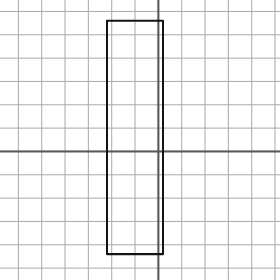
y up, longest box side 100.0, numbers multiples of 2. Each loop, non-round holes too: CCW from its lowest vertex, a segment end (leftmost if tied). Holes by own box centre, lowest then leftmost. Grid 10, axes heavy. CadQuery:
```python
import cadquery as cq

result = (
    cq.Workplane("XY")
    .moveTo(-22.0, -44.0)
    .lineTo(2.0, -44.0)
    .lineTo(2.0, 56.0)
    .lineTo(-22.0, 56.0)
    .close()
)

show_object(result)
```